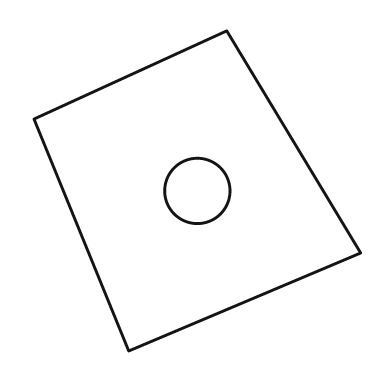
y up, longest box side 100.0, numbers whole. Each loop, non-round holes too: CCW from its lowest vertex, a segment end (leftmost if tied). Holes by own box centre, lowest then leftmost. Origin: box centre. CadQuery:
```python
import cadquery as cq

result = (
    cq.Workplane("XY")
    .moveTo(-21.0, -49.0)
    .lineTo(50.0, -19.0)
    .lineTo(9.0, 49.0)
    .lineTo(-50.0, 22.0)
    .close()
    .moveTo(0.0, 0.0)
    .circle(10.0)
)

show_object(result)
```